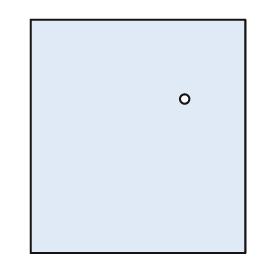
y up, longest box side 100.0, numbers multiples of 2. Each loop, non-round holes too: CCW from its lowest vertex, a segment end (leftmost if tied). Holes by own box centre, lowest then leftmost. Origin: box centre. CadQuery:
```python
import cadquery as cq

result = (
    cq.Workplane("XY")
    .moveTo(-46.0, -50.0)
    .lineTo(46.0, -50.0)
    .lineTo(46.0, 50.0)
    .lineTo(-46.0, 50.0)
    .close()
    .moveTo(20.0, 16.0)
    .circle(2.0)
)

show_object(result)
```